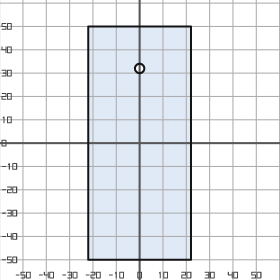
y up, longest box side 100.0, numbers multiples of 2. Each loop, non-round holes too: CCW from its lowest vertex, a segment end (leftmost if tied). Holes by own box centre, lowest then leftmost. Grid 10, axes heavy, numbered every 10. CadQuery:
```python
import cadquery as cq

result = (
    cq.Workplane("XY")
    .moveTo(-22.0, -50.0)
    .lineTo(22.0, -50.0)
    .lineTo(22.0, 50.0)
    .lineTo(-22.0, 50.0)
    .close()
    .moveTo(0.0, 32.0)
    .circle(2.0)
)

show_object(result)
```